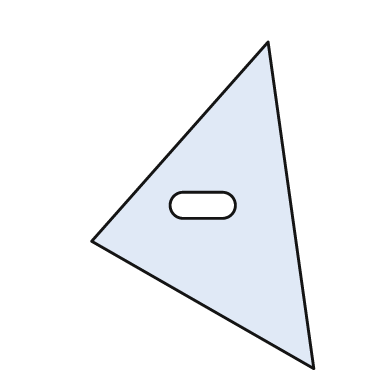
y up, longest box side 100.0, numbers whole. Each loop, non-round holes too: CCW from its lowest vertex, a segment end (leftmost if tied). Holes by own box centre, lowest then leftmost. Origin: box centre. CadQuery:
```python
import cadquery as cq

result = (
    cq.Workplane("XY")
    .moveTo(34.0, -50.0)
    .lineTo(20.0, 50.0)
    .lineTo(-34.0, -11.0)
    .close()
    .moveTo(-6.0, -4.0)
    .lineTo(6.0, -4.0)
    .threePointArc((10.0, 0.0), (6.0, 4.0))
    .lineTo(-6.0, 4.0)
    .threePointArc((-10.0, 0.0), (-6.0, -4.0))
    .close()
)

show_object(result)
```